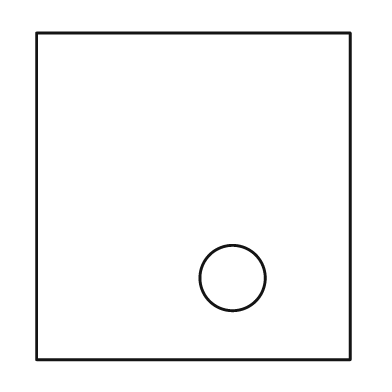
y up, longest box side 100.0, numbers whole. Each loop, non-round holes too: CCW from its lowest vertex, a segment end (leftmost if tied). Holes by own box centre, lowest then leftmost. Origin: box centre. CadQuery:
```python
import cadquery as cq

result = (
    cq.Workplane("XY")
    .moveTo(-48.0, -50.0)
    .lineTo(48.0, -50.0)
    .lineTo(48.0, 50.0)
    .lineTo(-48.0, 50.0)
    .close()
    .moveTo(12.0, -25.0)
    .circle(10.0)
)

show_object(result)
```